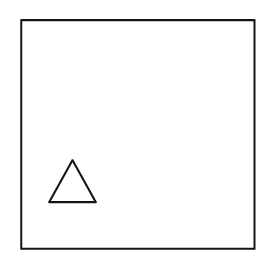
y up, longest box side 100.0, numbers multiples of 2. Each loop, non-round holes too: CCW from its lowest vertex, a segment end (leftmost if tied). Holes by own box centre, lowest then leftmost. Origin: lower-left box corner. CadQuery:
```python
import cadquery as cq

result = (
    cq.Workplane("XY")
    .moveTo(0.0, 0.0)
    .lineTo(100.0, 0.0)
    .lineTo(100.0, 98.0)
    .lineTo(0.0, 98.0)
    .close()
    .moveTo(12.0, 20.0)
    .lineTo(32.0, 20.0)
    .lineTo(22.0, 38.0)
    .close()
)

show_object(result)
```